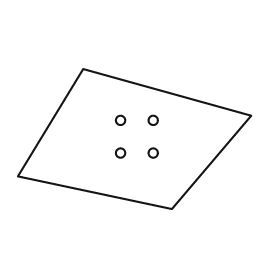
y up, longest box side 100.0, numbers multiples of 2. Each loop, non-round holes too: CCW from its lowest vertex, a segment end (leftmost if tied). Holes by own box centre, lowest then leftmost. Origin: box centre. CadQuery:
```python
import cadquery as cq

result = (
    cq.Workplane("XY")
    .moveTo(16.0, -30.0)
    .lineTo(50.0, 10.0)
    .lineTo(-22.0, 30.0)
    .lineTo(-50.0, -16.0)
    .close()
    .moveTo(-6.0, -6.0)
    .circle(2.0)
    .moveTo(8.0, -6.0)
    .circle(2.0)
    .moveTo(-6.0, 8.0)
    .circle(2.0)
    .moveTo(8.0, 8.0)
    .circle(2.0)
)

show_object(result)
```